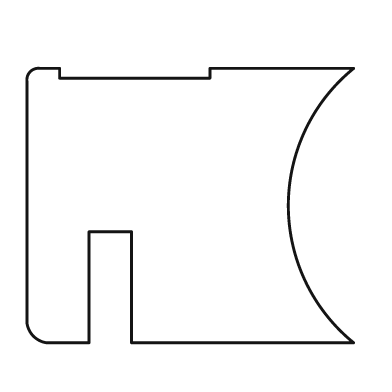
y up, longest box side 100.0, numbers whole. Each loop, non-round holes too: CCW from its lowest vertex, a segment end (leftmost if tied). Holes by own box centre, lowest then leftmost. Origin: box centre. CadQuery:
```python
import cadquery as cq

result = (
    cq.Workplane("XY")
    .moveTo(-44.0, -42.0)
    .lineTo(-31.0, -42.0)
    .lineTo(-31.0, -8.0)
    .lineTo(-18.0, -8.0)
    .lineTo(-18.0, -42.0)
    .lineTo(50.0, -42.0)
    .threePointArc((30.0, 0.0), (50.0, 42.0))
    .lineTo(6.0, 42.0)
    .lineTo(6.0, 39.0)
    .lineTo(-40.0, 39.0)
    .lineTo(-40.0, 42.0)
    .lineTo(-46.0, 42.0)
    .threePointArc((-49.0, 41.0), (-50.0, 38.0))
    .lineTo(-50.0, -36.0)
    .threePointArc((-48.0, -40.0), (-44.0, -42.0))
    .close()
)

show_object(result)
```